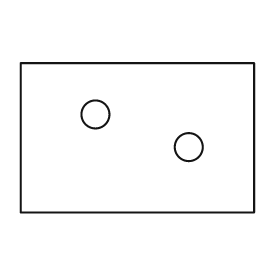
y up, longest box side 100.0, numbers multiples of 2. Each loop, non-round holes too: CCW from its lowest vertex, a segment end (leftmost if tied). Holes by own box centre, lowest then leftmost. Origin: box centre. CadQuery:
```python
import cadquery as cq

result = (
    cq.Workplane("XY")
    .moveTo(-50.0, -32.0)
    .lineTo(50.0, -32.0)
    .lineTo(50.0, 32.0)
    .lineTo(-50.0, 32.0)
    .close()
    .moveTo(22.0, -4.0)
    .circle(6.0)
    .moveTo(-18.0, 10.0)
    .circle(6.0)
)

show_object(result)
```